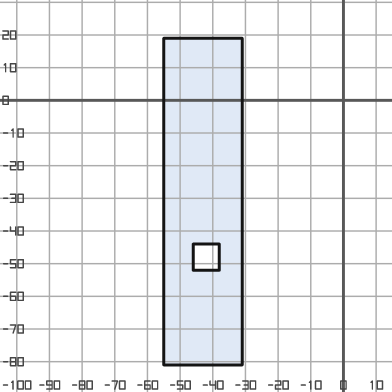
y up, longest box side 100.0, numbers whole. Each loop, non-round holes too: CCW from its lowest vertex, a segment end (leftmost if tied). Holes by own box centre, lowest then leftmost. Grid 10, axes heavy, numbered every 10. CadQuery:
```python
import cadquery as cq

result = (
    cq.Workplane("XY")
    .moveTo(-55.0, -81.0)
    .lineTo(-31.0, -81.0)
    .lineTo(-31.0, 19.0)
    .lineTo(-55.0, 19.0)
    .close()
    .moveTo(-46.0, -52.0)
    .lineTo(-38.0, -52.0)
    .lineTo(-38.0, -44.0)
    .lineTo(-46.0, -44.0)
    .close()
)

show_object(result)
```